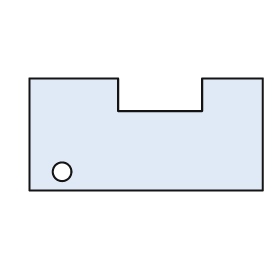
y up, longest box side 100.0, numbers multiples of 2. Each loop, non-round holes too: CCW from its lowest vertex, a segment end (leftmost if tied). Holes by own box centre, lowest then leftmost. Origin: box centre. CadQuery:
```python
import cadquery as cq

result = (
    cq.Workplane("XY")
    .moveTo(-50.0, -24.0)
    .lineTo(50.0, -24.0)
    .lineTo(50.0, 24.0)
    .lineTo(24.0, 24.0)
    .lineTo(24.0, 10.0)
    .lineTo(-12.0, 10.0)
    .lineTo(-12.0, 24.0)
    .lineTo(-50.0, 24.0)
    .close()
    .moveTo(-36.0, -16.0)
    .circle(4.0)
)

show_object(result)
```